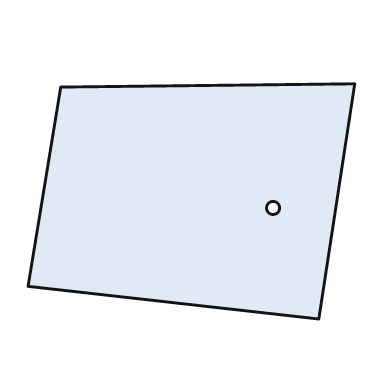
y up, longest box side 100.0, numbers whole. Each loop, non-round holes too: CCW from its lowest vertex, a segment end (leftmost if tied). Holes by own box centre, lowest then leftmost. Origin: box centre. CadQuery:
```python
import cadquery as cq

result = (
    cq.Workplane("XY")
    .moveTo(39.0, -36.0)
    .lineTo(50.0, 36.0)
    .lineTo(-40.0, 35.0)
    .lineTo(-50.0, -26.0)
    .close()
    .moveTo(25.0, -2.0)
    .circle(2.0)
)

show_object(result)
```